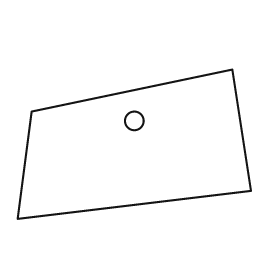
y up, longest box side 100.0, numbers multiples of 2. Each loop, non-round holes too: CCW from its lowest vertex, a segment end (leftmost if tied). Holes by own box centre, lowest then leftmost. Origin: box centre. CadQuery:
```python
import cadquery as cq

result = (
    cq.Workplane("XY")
    .moveTo(-50.0, -32.0)
    .lineTo(50.0, -20.0)
    .lineTo(42.0, 32.0)
    .lineTo(-44.0, 14.0)
    .close()
    .moveTo(0.0, 10.0)
    .circle(4.0)
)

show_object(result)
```